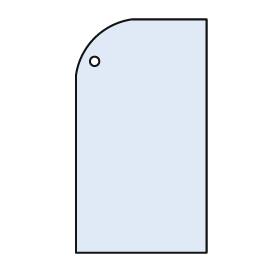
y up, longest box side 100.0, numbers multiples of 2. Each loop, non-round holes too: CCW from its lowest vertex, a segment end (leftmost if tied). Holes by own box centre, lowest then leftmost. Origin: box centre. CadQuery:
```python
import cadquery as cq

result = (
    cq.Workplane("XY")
    .moveTo(-28.0, -50.0)
    .lineTo(28.0, -50.0)
    .lineTo(28.0, 50.0)
    .lineTo(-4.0, 50.0)
    .threePointArc((-20.0, 42.0), (-28.0, 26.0))
    .close()
    .moveTo(-20.0, 32.0)
    .circle(2.0)
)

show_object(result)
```